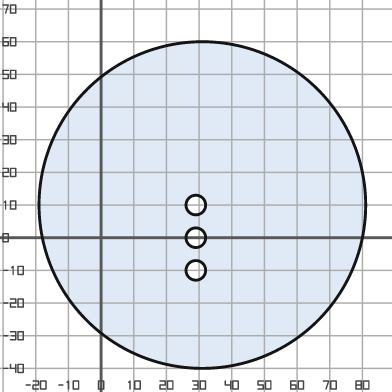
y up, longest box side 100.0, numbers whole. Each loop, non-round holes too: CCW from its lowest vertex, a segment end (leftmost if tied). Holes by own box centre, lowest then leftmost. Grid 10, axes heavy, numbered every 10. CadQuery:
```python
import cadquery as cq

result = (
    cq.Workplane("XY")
    .moveTo(31.0, 10.0)
    .circle(50.0)
    .moveTo(29.0, -10.0)
    .circle(3.0)
    .moveTo(29.0, 0.0)
    .circle(3.0)
    .moveTo(29.0, 10.0)
    .circle(3.0)
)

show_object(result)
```